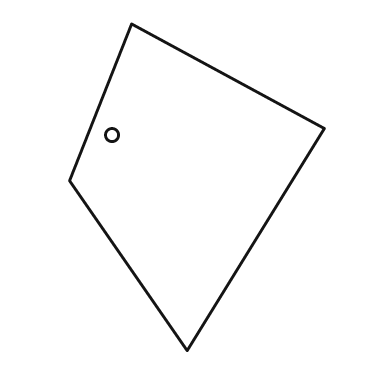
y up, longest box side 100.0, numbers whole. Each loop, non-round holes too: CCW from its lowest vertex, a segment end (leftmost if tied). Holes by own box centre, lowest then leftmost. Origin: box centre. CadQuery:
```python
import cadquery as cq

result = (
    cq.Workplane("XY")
    .moveTo(-3.0, -50.0)
    .lineTo(39.0, 18.0)
    .lineTo(-20.0, 50.0)
    .lineTo(-39.0, 2.0)
    .close()
    .moveTo(-26.0, 16.0)
    .circle(2.0)
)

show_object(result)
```